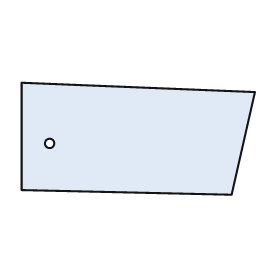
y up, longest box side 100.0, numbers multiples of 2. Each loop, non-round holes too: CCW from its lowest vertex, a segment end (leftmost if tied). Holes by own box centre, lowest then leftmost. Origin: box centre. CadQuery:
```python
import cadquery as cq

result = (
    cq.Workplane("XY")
    .moveTo(40.0, -24.0)
    .lineTo(50.0, 20.0)
    .lineTo(-50.0, 24.0)
    .lineTo(-50.0, -22.0)
    .close()
    .moveTo(-38.0, -2.0)
    .circle(2.0)
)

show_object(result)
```